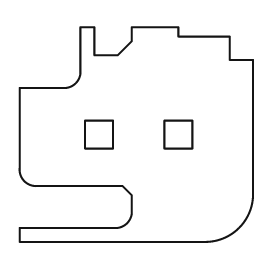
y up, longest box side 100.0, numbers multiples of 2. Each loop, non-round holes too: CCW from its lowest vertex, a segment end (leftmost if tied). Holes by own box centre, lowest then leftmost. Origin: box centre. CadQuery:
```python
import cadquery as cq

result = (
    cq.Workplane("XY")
    .moveTo(-50.0, -46.0)
    .lineTo(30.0, -46.0)
    .threePointArc((44.0, -40.0), (50.0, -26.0))
    .lineTo(50.0, 32.0)
    .lineTo(40.0, 32.0)
    .lineTo(40.0, 42.0)
    .lineTo(18.0, 42.0)
    .lineTo(18.0, 46.0)
    .lineTo(-2.0, 46.0)
    .lineTo(-2.0, 40.0)
    .lineTo(-8.0, 34.0)
    .lineTo(-18.0, 34.0)
    .lineTo(-18.0, 46.0)
    .lineTo(-24.0, 46.0)
    .lineTo(-24.0, 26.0)
    .threePointArc((-26.0, 22.0), (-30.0, 20.0))
    .lineTo(-50.0, 20.0)
    .lineTo(-50.0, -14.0)
    .threePointArc((-48.0, -20.0), (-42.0, -22.0))
    .lineTo(-6.0, -22.0)
    .lineTo(-2.0, -26.0)
    .lineTo(-2.0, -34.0)
    .threePointArc((-4.0, -38.0), (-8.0, -40.0))
    .lineTo(-50.0, -40.0)
    .close()
    .moveTo(-22.0, -6.0)
    .lineTo(-10.0, -6.0)
    .lineTo(-10.0, 6.0)
    .lineTo(-22.0, 6.0)
    .close()
    .moveTo(12.0, -6.0)
    .lineTo(24.0, -6.0)
    .lineTo(24.0, 6.0)
    .lineTo(12.0, 6.0)
    .close()
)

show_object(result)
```